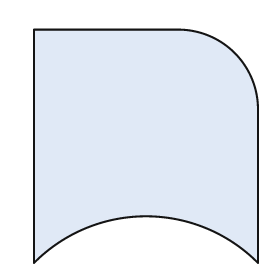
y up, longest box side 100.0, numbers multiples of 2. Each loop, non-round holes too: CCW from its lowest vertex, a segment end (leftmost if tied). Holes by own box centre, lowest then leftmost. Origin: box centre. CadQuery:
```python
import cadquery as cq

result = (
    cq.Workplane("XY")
    .moveTo(-48.0, -50.0)
    .threePointArc((0.0, -30.0), (48.0, -50.0))
    .lineTo(48.0, 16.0)
    .threePointArc((38.0, 40.0), (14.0, 50.0))
    .lineTo(-48.0, 50.0)
    .close()
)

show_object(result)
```